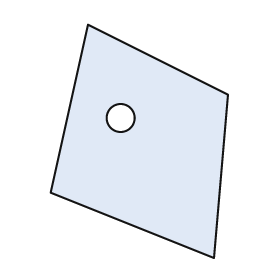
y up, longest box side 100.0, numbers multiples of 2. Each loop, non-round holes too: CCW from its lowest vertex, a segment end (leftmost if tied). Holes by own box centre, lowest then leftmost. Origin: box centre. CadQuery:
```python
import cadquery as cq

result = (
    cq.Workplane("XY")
    .moveTo(32.0, -50.0)
    .lineTo(38.0, 20.0)
    .lineTo(-22.0, 50.0)
    .lineTo(-38.0, -22.0)
    .close()
    .moveTo(-8.0, 10.0)
    .circle(6.0)
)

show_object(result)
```